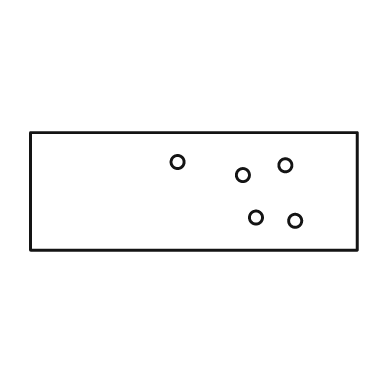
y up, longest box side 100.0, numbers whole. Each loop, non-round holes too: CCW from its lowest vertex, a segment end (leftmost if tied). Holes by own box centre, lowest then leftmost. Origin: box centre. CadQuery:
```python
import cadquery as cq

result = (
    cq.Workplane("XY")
    .moveTo(-50.0, -18.0)
    .lineTo(50.0, -18.0)
    .lineTo(50.0, 18.0)
    .lineTo(-50.0, 18.0)
    .close()
    .moveTo(31.0, -9.0)
    .circle(2.0)
    .moveTo(19.0, -8.0)
    .circle(2.0)
    .moveTo(15.0, 5.0)
    .circle(2.0)
    .moveTo(28.0, 8.0)
    .circle(2.0)
    .moveTo(-5.0, 9.0)
    .circle(2.0)
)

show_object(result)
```